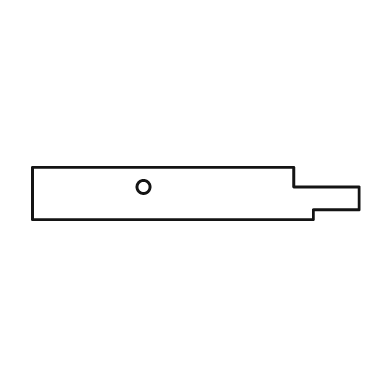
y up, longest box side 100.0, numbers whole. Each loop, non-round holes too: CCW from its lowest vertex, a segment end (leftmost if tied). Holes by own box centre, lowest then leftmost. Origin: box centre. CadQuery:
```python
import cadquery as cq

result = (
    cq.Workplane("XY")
    .moveTo(-50.0, -8.0)
    .lineTo(36.0, -8.0)
    .lineTo(36.0, -5.0)
    .lineTo(50.0, -5.0)
    .lineTo(50.0, 2.0)
    .lineTo(30.0, 2.0)
    .lineTo(30.0, 8.0)
    .lineTo(-50.0, 8.0)
    .close()
    .moveTo(-16.0, 2.0)
    .circle(2.0)
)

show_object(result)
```